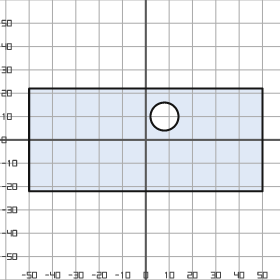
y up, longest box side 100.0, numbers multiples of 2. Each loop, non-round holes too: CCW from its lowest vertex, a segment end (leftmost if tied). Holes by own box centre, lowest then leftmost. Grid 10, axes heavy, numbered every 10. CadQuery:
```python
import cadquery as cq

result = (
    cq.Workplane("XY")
    .moveTo(-50.0, -22.0)
    .lineTo(50.0, -22.0)
    .lineTo(50.0, 22.0)
    .lineTo(-50.0, 22.0)
    .close()
    .moveTo(8.0, 10.0)
    .circle(6.0)
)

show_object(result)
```